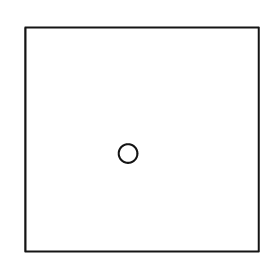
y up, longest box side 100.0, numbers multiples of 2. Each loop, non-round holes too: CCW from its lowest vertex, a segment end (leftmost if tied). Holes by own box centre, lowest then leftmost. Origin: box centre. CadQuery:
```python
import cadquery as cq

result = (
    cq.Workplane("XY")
    .moveTo(-50.0, -48.0)
    .lineTo(50.0, -48.0)
    .lineTo(50.0, 48.0)
    .lineTo(-50.0, 48.0)
    .close()
    .moveTo(-6.0, -6.0)
    .circle(4.0)
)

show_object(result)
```